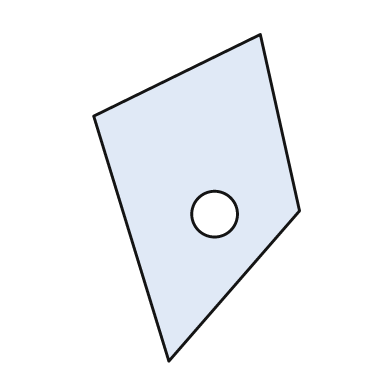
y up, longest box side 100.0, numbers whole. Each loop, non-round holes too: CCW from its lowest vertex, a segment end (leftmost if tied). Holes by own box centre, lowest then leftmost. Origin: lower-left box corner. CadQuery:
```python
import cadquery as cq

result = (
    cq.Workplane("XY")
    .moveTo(23.0, 0.0)
    .lineTo(63.0, 46.0)
    .lineTo(51.0, 100.0)
    .lineTo(0.0, 75.0)
    .close()
    .moveTo(37.0, 45.0)
    .circle(7.0)
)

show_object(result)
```